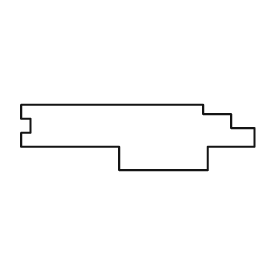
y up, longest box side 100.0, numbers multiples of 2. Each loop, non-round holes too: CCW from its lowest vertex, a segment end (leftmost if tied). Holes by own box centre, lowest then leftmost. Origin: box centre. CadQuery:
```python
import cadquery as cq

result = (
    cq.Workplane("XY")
    .moveTo(-8.0, -14.0)
    .lineTo(30.0, -14.0)
    .lineTo(30.0, -4.0)
    .lineTo(50.0, -4.0)
    .lineTo(50.0, 4.0)
    .lineTo(40.0, 4.0)
    .lineTo(40.0, 10.0)
    .lineTo(28.0, 10.0)
    .lineTo(28.0, 14.0)
    .lineTo(-50.0, 14.0)
    .lineTo(-50.0, 8.0)
    .lineTo(-46.0, 8.0)
    .lineTo(-46.0, 2.0)
    .lineTo(-50.0, 2.0)
    .lineTo(-50.0, -4.0)
    .lineTo(-8.0, -4.0)
    .close()
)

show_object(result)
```